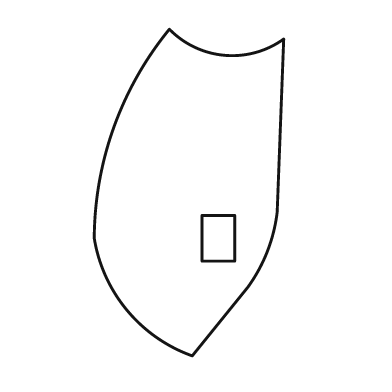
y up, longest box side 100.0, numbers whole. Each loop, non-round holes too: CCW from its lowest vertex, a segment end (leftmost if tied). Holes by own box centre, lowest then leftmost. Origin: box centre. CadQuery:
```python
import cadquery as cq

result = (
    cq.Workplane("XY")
    .moveTo(1.0, -50.0)
    .lineTo(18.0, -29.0)
    .threePointArc((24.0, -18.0), (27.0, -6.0))
    .lineTo(29.0, 47.0)
    .threePointArc((11.0, 42.0), (-6.0, 50.0))
    .threePointArc((-23.0, 20.0), (-29.0, -14.0))
    .threePointArc((-19.0, -36.0), (1.0, -50.0))
    .close()
    .moveTo(4.0, -21.0)
    .lineTo(14.0, -21.0)
    .lineTo(14.0, -7.0)
    .lineTo(4.0, -7.0)
    .close()
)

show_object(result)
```